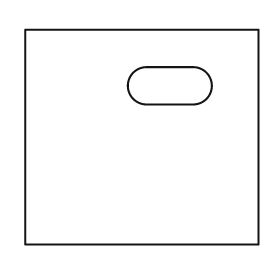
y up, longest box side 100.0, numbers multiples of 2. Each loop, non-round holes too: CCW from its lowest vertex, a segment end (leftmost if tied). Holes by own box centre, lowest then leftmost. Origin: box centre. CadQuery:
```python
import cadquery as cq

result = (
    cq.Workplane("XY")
    .moveTo(-50.0, -46.0)
    .lineTo(50.0, -46.0)
    .lineTo(50.0, 46.0)
    .lineTo(-50.0, 46.0)
    .close()
    .moveTo(2.0, 14.0)
    .lineTo(22.0, 14.0)
    .threePointArc((30.0, 22.0), (22.0, 30.0))
    .lineTo(2.0, 30.0)
    .threePointArc((-6.0, 22.0), (2.0, 14.0))
    .close()
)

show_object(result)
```